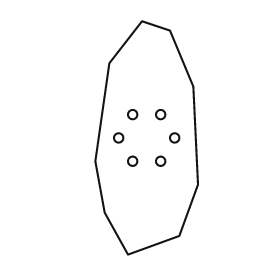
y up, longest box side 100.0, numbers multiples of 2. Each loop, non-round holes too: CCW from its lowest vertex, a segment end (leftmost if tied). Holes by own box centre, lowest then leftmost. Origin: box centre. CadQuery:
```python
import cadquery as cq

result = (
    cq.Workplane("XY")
    .moveTo(-8.0, -50.0)
    .lineTo(14.0, -42.0)
    .lineTo(22.0, -20.0)
    .lineTo(20.0, 22.0)
    .lineTo(10.0, 46.0)
    .lineTo(-2.0, 50.0)
    .lineTo(-16.0, 32.0)
    .lineTo(-22.0, -10.0)
    .lineTo(-18.0, -32.0)
    .close()
    .moveTo(-6.0, -10.0)
    .circle(2.0)
    .moveTo(6.0, -10.0)
    .circle(2.0)
    .moveTo(-12.0, 0.0)
    .circle(2.0)
    .moveTo(12.0, 0.0)
    .circle(2.0)
    .moveTo(-6.0, 10.0)
    .circle(2.0)
    .moveTo(6.0, 10.0)
    .circle(2.0)
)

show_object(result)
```